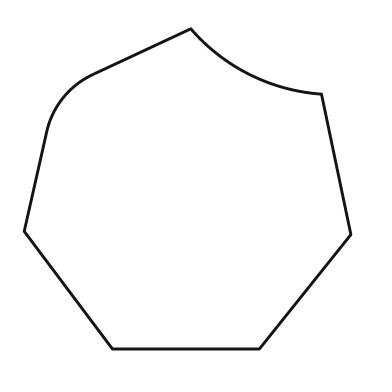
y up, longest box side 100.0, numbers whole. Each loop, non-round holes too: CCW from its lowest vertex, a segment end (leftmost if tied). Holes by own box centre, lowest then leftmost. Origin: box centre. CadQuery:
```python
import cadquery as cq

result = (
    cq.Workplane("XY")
    .moveTo(-23.0, -49.0)
    .lineTo(22.0, -49.0)
    .lineTo(50.0, -14.0)
    .lineTo(41.0, 29.0)
    .threePointArc((19.0, 35.0), (1.0, 49.0))
    .lineTo(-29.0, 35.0)
    .threePointArc((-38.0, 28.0), (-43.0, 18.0))
    .lineTo(-50.0, -13.0)
    .close()
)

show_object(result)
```